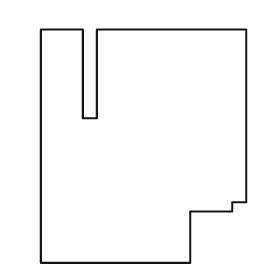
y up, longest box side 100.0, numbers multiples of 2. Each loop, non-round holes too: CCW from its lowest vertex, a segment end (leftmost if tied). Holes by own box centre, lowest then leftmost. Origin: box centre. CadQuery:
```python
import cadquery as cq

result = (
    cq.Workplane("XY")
    .moveTo(-44.0, -50.0)
    .lineTo(20.0, -50.0)
    .lineTo(20.0, -28.0)
    .lineTo(38.0, -28.0)
    .lineTo(38.0, -24.0)
    .lineTo(44.0, -24.0)
    .lineTo(44.0, 50.0)
    .lineTo(-20.0, 50.0)
    .lineTo(-20.0, 12.0)
    .lineTo(-26.0, 12.0)
    .lineTo(-26.0, 50.0)
    .lineTo(-44.0, 50.0)
    .close()
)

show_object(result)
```